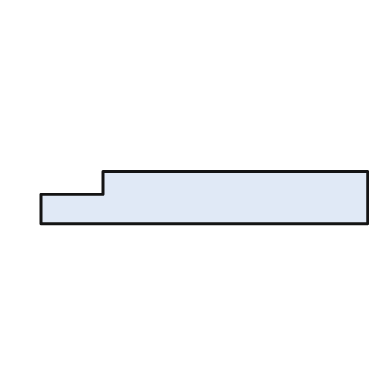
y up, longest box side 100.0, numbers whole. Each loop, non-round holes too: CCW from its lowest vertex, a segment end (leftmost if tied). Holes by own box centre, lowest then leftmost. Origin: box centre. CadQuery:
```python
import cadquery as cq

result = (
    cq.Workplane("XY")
    .moveTo(-50.0, -8.0)
    .lineTo(50.0, -8.0)
    .lineTo(50.0, 8.0)
    .lineTo(-31.0, 8.0)
    .lineTo(-31.0, 1.0)
    .lineTo(-50.0, 1.0)
    .close()
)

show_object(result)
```